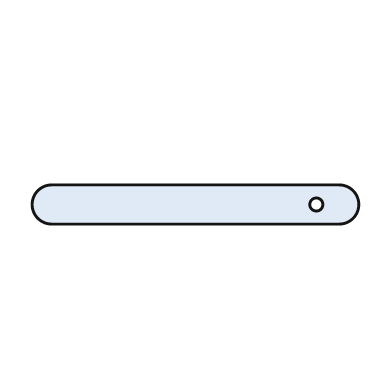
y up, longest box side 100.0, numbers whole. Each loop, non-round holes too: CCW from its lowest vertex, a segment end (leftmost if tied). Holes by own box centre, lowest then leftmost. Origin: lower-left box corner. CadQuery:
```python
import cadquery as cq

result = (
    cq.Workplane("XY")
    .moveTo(6.0, 0.0)
    .lineTo(94.0, 0.0)
    .threePointArc((100.0, 6.0), (94.0, 12.0))
    .lineTo(6.0, 12.0)
    .threePointArc((0.0, 6.0), (6.0, 0.0))
    .close()
    .moveTo(87.0, 6.0)
    .circle(2.0)
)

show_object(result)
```